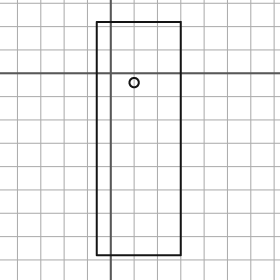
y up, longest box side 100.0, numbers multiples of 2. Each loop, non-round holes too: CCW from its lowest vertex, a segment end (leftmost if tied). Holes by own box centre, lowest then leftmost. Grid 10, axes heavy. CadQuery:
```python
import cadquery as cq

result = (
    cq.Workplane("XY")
    .moveTo(-6.0, -78.0)
    .lineTo(30.0, -78.0)
    .lineTo(30.0, 22.0)
    .lineTo(-6.0, 22.0)
    .close()
    .moveTo(10.0, -4.0)
    .circle(2.0)
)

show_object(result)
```